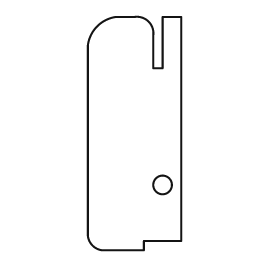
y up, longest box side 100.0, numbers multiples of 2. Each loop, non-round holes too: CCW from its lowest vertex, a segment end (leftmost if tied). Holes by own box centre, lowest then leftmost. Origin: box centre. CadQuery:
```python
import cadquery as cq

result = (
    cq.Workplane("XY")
    .moveTo(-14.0, -50.0)
    .lineTo(4.0, -50.0)
    .lineTo(4.0, -46.0)
    .lineTo(20.0, -46.0)
    .lineTo(20.0, 50.0)
    .lineTo(12.0, 50.0)
    .lineTo(12.0, 28.0)
    .lineTo(8.0, 28.0)
    .lineTo(8.0, 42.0)
    .threePointArc((6.0, 48.0), (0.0, 50.0))
    .lineTo(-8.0, 50.0)
    .threePointArc((-16.0, 46.0), (-20.0, 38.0))
    .lineTo(-20.0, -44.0)
    .threePointArc((-18.0, -48.0), (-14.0, -50.0))
    .close()
    .moveTo(12.0, -22.0)
    .circle(4.0)
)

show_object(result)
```